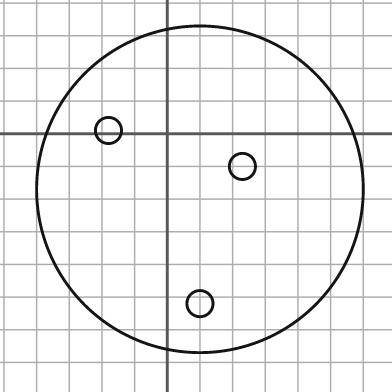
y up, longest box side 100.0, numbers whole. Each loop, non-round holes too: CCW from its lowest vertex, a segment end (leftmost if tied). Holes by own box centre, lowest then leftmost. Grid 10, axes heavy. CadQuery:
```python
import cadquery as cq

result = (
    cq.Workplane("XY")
    .moveTo(10.0, -17.0)
    .circle(50.0)
    .moveTo(10.0, -52.0)
    .circle(4.0)
    .moveTo(23.0, -10.0)
    .circle(4.0)
    .moveTo(-18.0, 1.0)
    .circle(4.0)
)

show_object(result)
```